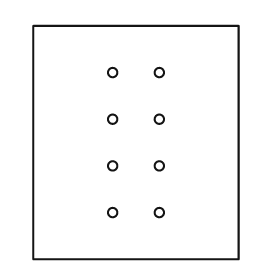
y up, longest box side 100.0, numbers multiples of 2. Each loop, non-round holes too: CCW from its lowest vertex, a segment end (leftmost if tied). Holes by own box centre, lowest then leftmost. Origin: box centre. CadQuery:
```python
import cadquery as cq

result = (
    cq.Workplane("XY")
    .moveTo(-44.0, -50.0)
    .lineTo(44.0, -50.0)
    .lineTo(44.0, 50.0)
    .lineTo(-44.0, 50.0)
    .close()
    .moveTo(-10.0, -30.0)
    .circle(2.0)
    .moveTo(10.0, -30.0)
    .circle(2.0)
    .moveTo(-10.0, -10.0)
    .circle(2.0)
    .moveTo(10.0, -10.0)
    .circle(2.0)
    .moveTo(-10.0, 10.0)
    .circle(2.0)
    .moveTo(10.0, 10.0)
    .circle(2.0)
    .moveTo(-10.0, 30.0)
    .circle(2.0)
    .moveTo(10.0, 30.0)
    .circle(2.0)
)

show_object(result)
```